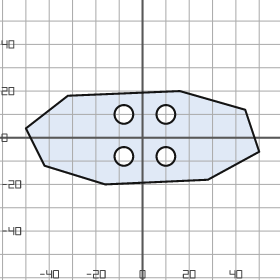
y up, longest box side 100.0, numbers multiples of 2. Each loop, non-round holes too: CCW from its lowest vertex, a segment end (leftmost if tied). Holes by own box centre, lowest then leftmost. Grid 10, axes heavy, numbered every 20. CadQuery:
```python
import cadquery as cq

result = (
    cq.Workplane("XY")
    .moveTo(-16.0, -20.0)
    .lineTo(28.0, -18.0)
    .lineTo(50.0, -6.0)
    .lineTo(44.0, 12.0)
    .lineTo(16.0, 20.0)
    .lineTo(-32.0, 18.0)
    .lineTo(-50.0, 4.0)
    .lineTo(-42.0, -12.0)
    .close()
    .moveTo(-8.0, -8.0)
    .circle(4.0)
    .moveTo(10.0, -8.0)
    .circle(4.0)
    .moveTo(-8.0, 10.0)
    .circle(4.0)
    .moveTo(10.0, 10.0)
    .circle(4.0)
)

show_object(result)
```